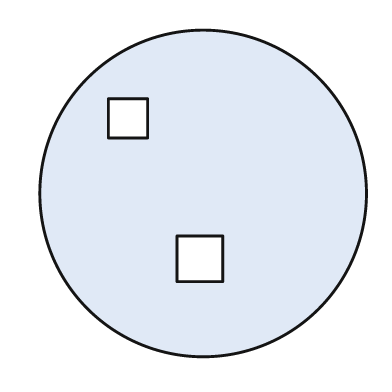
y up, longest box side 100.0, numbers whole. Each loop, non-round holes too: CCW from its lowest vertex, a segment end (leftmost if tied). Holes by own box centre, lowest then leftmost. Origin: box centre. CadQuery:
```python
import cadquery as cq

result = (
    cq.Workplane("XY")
    .moveTo(0.0, 0.0)
    .circle(50.0)
    .moveTo(-8.0, -27.0)
    .lineTo(6.0, -27.0)
    .lineTo(6.0, -13.0)
    .lineTo(-8.0, -13.0)
    .close()
    .moveTo(-29.0, 17.0)
    .lineTo(-17.0, 17.0)
    .lineTo(-17.0, 29.0)
    .lineTo(-29.0, 29.0)
    .close()
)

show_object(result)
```